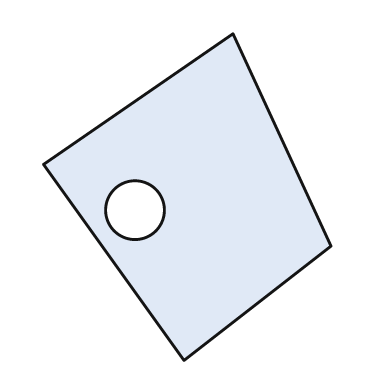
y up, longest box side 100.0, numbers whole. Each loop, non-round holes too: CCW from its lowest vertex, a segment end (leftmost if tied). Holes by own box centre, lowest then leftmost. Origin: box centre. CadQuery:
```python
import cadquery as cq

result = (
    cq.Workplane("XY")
    .moveTo(-1.0, -50.0)
    .lineTo(44.0, -15.0)
    .lineTo(14.0, 50.0)
    .lineTo(-44.0, 10.0)
    .close()
    .moveTo(-16.0, -4.0)
    .circle(9.0)
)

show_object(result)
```